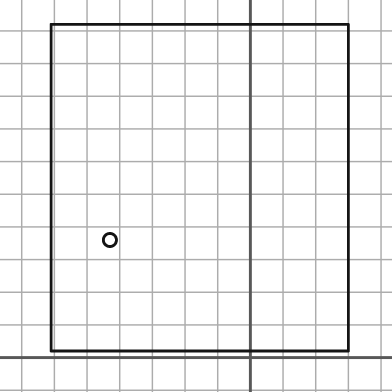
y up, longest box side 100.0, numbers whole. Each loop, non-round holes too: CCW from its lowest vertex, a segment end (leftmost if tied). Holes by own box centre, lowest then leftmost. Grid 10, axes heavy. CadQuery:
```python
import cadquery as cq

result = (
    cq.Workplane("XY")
    .moveTo(-61.0, 2.0)
    .lineTo(30.0, 2.0)
    .lineTo(30.0, 102.0)
    .lineTo(-61.0, 102.0)
    .close()
    .moveTo(-43.0, 36.0)
    .circle(2.0)
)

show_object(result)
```